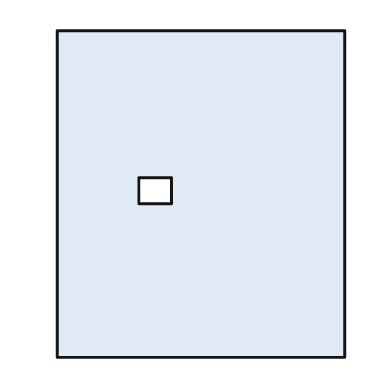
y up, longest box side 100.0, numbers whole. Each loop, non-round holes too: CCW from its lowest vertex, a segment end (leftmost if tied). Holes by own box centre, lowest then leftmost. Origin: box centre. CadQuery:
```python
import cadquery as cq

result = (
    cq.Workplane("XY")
    .moveTo(-44.0, -50.0)
    .lineTo(44.0, -50.0)
    .lineTo(44.0, 50.0)
    .lineTo(-44.0, 50.0)
    .close()
    .moveTo(-19.0, -3.0)
    .lineTo(-9.0, -3.0)
    .lineTo(-9.0, 5.0)
    .lineTo(-19.0, 5.0)
    .close()
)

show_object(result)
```